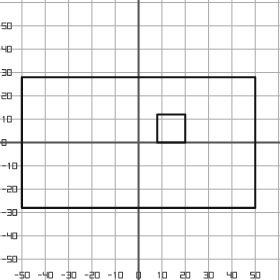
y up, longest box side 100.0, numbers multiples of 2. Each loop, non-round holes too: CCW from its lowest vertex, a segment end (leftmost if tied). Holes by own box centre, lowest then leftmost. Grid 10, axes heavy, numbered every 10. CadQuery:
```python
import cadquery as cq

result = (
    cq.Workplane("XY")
    .moveTo(-50.0, -28.0)
    .lineTo(50.0, -28.0)
    .lineTo(50.0, 28.0)
    .lineTo(-50.0, 28.0)
    .close()
    .moveTo(8.0, 0.0)
    .lineTo(20.0, 0.0)
    .lineTo(20.0, 12.0)
    .lineTo(8.0, 12.0)
    .close()
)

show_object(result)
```